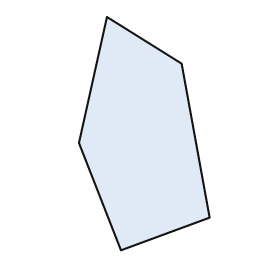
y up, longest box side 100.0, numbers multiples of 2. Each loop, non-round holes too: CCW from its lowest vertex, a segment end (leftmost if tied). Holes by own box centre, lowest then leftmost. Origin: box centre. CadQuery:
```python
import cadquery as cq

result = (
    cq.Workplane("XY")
    .moveTo(-10.0, -50.0)
    .lineTo(28.0, -36.0)
    .lineTo(16.0, 30.0)
    .lineTo(-16.0, 50.0)
    .lineTo(-28.0, -4.0)
    .close()
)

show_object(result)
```